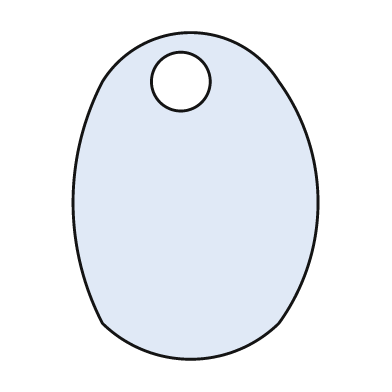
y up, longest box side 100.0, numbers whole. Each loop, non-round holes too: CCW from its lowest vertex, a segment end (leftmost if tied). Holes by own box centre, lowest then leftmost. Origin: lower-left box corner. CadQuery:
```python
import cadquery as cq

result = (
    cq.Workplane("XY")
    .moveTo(9.0, 11.0)
    .threePointArc((36.0, 0.0), (63.0, 11.0))
    .threePointArc((75.0, 48.0), (63.0, 85.0))
    .threePointArc((36.0, 100.0), (9.0, 85.0))
    .threePointArc((0.0, 48.0), (9.0, 11.0))
    .close()
    .moveTo(33.0, 85.0)
    .circle(9.0)
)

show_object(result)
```